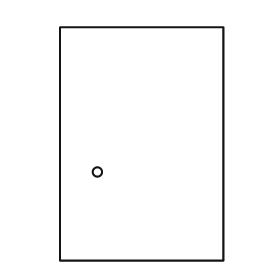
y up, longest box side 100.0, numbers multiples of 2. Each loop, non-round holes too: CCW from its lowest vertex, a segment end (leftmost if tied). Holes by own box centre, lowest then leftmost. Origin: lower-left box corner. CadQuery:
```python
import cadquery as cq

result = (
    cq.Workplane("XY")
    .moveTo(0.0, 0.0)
    .lineTo(70.0, 0.0)
    .lineTo(70.0, 100.0)
    .lineTo(0.0, 100.0)
    .close()
    .moveTo(16.0, 38.0)
    .circle(2.0)
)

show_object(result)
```